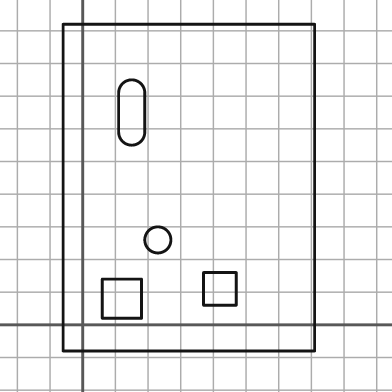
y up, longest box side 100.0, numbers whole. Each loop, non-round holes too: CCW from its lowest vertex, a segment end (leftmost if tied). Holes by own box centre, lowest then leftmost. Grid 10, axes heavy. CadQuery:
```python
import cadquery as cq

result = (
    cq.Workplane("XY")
    .moveTo(-6.0, -8.0)
    .lineTo(71.0, -8.0)
    .lineTo(71.0, 92.0)
    .lineTo(-6.0, 92.0)
    .close()
    .moveTo(6.0, 2.0)
    .lineTo(18.0, 2.0)
    .lineTo(18.0, 14.0)
    .lineTo(6.0, 14.0)
    .close()
    .moveTo(37.0, 6.0)
    .lineTo(47.0, 6.0)
    .lineTo(47.0, 16.0)
    .lineTo(37.0, 16.0)
    .close()
    .moveTo(23.0, 26.0)
    .circle(4.0)
    .moveTo(11.0, 59.0)
    .threePointArc((15.0, 55.0), (19.0, 59.0))
    .lineTo(19.0, 71.0)
    .threePointArc((15.0, 75.0), (11.0, 71.0))
    .close()
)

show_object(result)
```